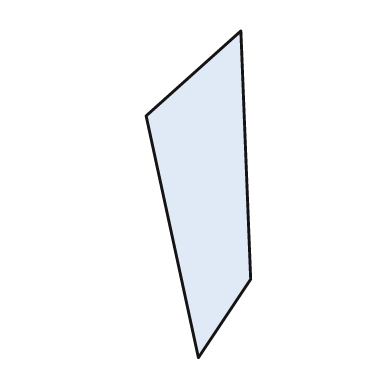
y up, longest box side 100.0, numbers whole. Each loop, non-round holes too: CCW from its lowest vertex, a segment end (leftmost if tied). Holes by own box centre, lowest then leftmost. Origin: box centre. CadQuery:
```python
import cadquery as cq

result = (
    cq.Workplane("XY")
    .moveTo(0.0, -50.0)
    .lineTo(16.0, -26.0)
    .lineTo(13.0, 50.0)
    .lineTo(-16.0, 24.0)
    .close()
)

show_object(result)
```